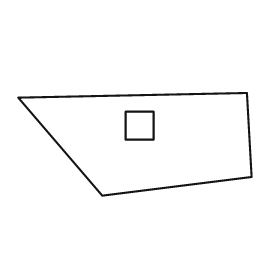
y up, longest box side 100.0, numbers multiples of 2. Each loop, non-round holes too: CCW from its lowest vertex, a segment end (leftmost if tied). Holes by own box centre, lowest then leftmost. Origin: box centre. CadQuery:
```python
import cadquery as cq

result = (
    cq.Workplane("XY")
    .moveTo(-14.0, -22.0)
    .lineTo(50.0, -14.0)
    .lineTo(48.0, 22.0)
    .lineTo(-50.0, 20.0)
    .close()
    .moveTo(-4.0, 2.0)
    .lineTo(8.0, 2.0)
    .lineTo(8.0, 14.0)
    .lineTo(-4.0, 14.0)
    .close()
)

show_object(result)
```